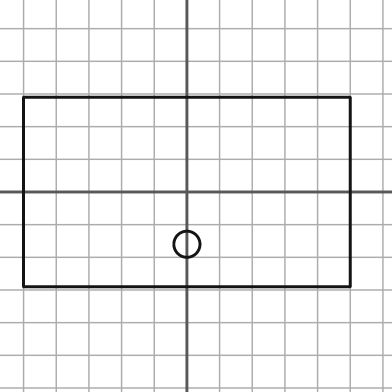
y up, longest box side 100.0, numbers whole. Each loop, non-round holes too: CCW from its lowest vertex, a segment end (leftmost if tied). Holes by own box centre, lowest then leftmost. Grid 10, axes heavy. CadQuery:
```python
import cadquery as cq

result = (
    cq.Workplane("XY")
    .moveTo(-50.0, -29.0)
    .lineTo(50.0, -29.0)
    .lineTo(50.0, 29.0)
    .lineTo(-50.0, 29.0)
    .close()
    .moveTo(0.0, -16.0)
    .circle(4.0)
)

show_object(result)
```